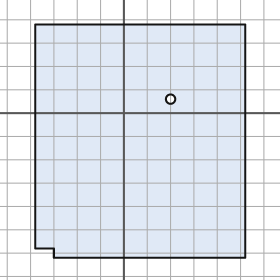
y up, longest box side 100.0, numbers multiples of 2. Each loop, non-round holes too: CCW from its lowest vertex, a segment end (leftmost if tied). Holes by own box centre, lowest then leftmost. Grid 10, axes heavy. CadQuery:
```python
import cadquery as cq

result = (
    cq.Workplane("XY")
    .moveTo(-30.0, -62.0)
    .lineTo(52.0, -62.0)
    .lineTo(52.0, 38.0)
    .lineTo(-38.0, 38.0)
    .lineTo(-38.0, -58.0)
    .lineTo(-30.0, -58.0)
    .close()
    .moveTo(20.0, 6.0)
    .circle(2.0)
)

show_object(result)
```